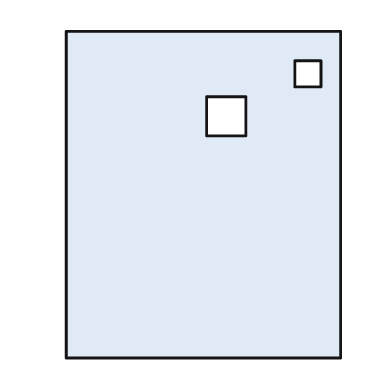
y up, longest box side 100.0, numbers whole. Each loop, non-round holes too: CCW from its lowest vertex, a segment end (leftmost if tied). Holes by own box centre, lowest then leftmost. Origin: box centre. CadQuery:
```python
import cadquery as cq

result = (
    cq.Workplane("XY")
    .moveTo(-42.0, -50.0)
    .lineTo(42.0, -50.0)
    .lineTo(42.0, 50.0)
    .lineTo(-42.0, 50.0)
    .close()
    .moveTo(1.0, 18.0)
    .lineTo(13.0, 18.0)
    .lineTo(13.0, 30.0)
    .lineTo(1.0, 30.0)
    .close()
    .moveTo(28.0, 33.0)
    .lineTo(36.0, 33.0)
    .lineTo(36.0, 41.0)
    .lineTo(28.0, 41.0)
    .close()
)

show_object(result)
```